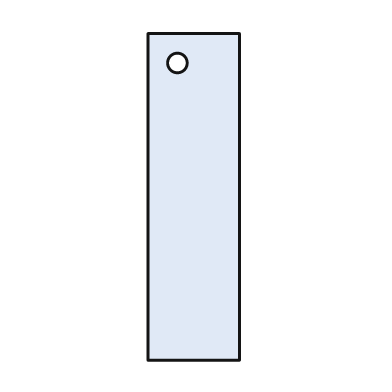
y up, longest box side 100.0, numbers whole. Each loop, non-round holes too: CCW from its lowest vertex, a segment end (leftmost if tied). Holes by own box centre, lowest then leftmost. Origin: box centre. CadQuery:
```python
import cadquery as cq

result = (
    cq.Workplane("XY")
    .moveTo(-14.0, -50.0)
    .lineTo(14.0, -50.0)
    .lineTo(14.0, 50.0)
    .lineTo(-14.0, 50.0)
    .close()
    .moveTo(-5.0, 41.0)
    .circle(3.0)
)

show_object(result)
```